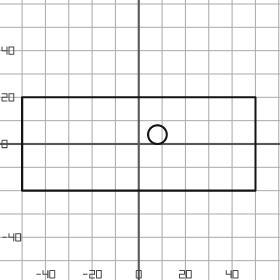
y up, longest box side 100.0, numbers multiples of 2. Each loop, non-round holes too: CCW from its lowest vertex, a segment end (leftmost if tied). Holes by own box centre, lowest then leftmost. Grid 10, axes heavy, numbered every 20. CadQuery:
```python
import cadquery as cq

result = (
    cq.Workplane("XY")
    .moveTo(-50.0, -20.0)
    .lineTo(50.0, -20.0)
    .lineTo(50.0, 20.0)
    .lineTo(-50.0, 20.0)
    .close()
    .moveTo(8.0, 4.0)
    .circle(4.0)
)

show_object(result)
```